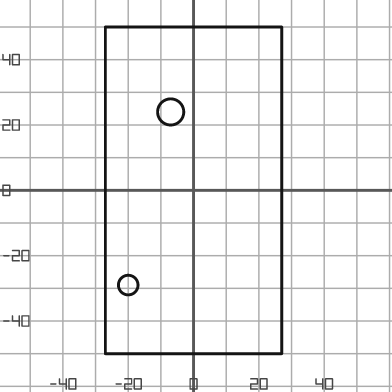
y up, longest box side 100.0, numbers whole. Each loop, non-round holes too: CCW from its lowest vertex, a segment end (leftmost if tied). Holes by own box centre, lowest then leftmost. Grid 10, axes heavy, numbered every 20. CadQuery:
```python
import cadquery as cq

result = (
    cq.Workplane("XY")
    .moveTo(-27.0, -50.0)
    .lineTo(27.0, -50.0)
    .lineTo(27.0, 50.0)
    .lineTo(-27.0, 50.0)
    .close()
    .moveTo(-20.0, -29.0)
    .circle(3.0)
    .moveTo(-7.0, 24.0)
    .circle(4.0)
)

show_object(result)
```